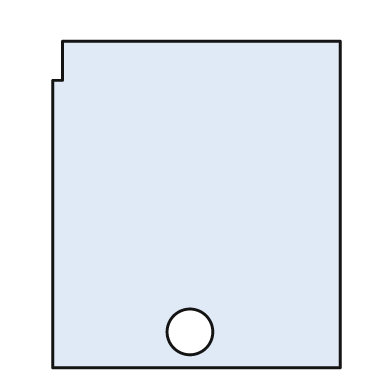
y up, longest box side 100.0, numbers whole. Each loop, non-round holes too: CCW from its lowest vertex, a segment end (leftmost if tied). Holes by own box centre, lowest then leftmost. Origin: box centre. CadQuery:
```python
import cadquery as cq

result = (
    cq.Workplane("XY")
    .moveTo(-44.0, -50.0)
    .lineTo(44.0, -50.0)
    .lineTo(44.0, 50.0)
    .lineTo(-41.0, 50.0)
    .lineTo(-41.0, 38.0)
    .lineTo(-44.0, 38.0)
    .close()
    .moveTo(-2.0, -39.0)
    .circle(7.0)
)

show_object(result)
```